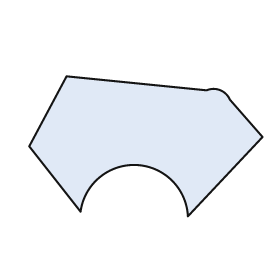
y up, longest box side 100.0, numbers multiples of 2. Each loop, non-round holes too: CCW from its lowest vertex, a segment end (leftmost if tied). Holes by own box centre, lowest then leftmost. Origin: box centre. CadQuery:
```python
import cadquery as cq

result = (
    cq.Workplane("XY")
    .moveTo(18.0, -30.0)
    .lineTo(50.0, 4.0)
    .lineTo(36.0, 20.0)
    .threePointArc((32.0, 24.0), (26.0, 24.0))
    .lineTo(-34.0, 30.0)
    .lineTo(-50.0, 0.0)
    .lineTo(-28.0, -28.0)
    .threePointArc((-4.0, -8.0), (18.0, -30.0))
    .close()
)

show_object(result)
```